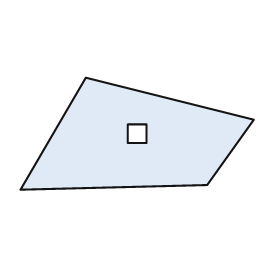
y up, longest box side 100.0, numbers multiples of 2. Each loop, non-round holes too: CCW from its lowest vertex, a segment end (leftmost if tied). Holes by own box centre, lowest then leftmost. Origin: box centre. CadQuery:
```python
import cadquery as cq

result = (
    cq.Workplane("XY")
    .moveTo(-50.0, -24.0)
    .lineTo(30.0, -22.0)
    .lineTo(50.0, 6.0)
    .lineTo(-22.0, 24.0)
    .close()
    .moveTo(-4.0, -4.0)
    .lineTo(4.0, -4.0)
    .lineTo(4.0, 4.0)
    .lineTo(-4.0, 4.0)
    .close()
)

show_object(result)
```